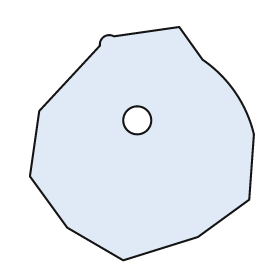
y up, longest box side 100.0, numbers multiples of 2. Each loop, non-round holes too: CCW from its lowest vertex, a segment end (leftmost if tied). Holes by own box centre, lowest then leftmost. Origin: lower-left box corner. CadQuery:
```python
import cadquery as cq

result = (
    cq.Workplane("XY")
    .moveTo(40.0, 0.0)
    .lineTo(72.0, 10.0)
    .lineTo(94.0, 26.0)
    .lineTo(96.0, 54.0)
    .threePointArc((88.0, 72.0), (74.0, 86.0))
    .lineTo(64.0, 100.0)
    .lineTo(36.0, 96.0)
    .threePointArc((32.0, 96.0), (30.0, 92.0))
    .lineTo(4.0, 64.0)
    .lineTo(0.0, 36.0)
    .lineTo(16.0, 14.0)
    .close()
    .moveTo(46.0, 60.0)
    .circle(6.0)
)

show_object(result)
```